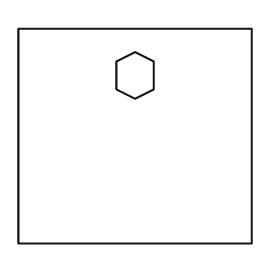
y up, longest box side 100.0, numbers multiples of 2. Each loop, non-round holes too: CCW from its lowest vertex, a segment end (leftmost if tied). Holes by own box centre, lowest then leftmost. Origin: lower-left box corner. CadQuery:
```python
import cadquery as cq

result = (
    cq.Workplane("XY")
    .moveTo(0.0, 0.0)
    .lineTo(100.0, 0.0)
    .lineTo(100.0, 92.0)
    .lineTo(0.0, 92.0)
    .close()
    .moveTo(50.0, 62.0)
    .lineTo(58.0, 66.0)
    .lineTo(58.0, 78.0)
    .lineTo(50.0, 82.0)
    .lineTo(42.0, 78.0)
    .lineTo(42.0, 66.0)
    .close()
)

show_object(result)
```